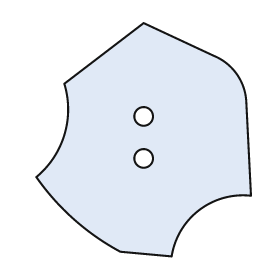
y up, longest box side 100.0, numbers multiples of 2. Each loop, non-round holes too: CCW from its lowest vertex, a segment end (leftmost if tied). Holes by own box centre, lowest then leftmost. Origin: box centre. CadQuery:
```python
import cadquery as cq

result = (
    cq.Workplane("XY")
    .moveTo(12.0, -50.0)
    .threePointArc((24.0, -30.0), (46.0, -24.0))
    .lineTo(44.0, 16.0)
    .threePointArc((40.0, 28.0), (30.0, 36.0))
    .lineTo(0.0, 50.0)
    .lineTo(-34.0, 24.0)
    .threePointArc((-34.0, 2.0), (-46.0, -16.0))
    .threePointArc((-30.0, -34.0), (-10.0, -48.0))
    .close()
    .moveTo(0.0, -8.0)
    .circle(4.0)
    .moveTo(0.0, 10.0)
    .circle(4.0)
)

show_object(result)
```